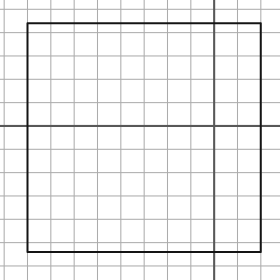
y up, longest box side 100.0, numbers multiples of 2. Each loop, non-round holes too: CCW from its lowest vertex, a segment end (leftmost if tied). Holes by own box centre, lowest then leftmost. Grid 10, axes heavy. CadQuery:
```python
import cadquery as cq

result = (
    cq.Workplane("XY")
    .moveTo(-80.0, -54.0)
    .lineTo(20.0, -54.0)
    .lineTo(20.0, 44.0)
    .lineTo(-80.0, 44.0)
    .close()
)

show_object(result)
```